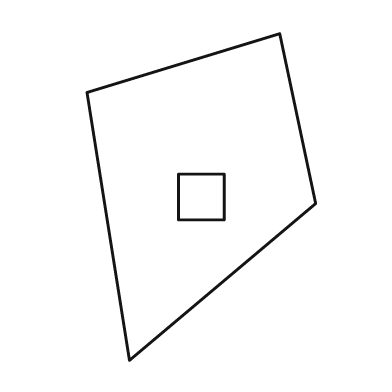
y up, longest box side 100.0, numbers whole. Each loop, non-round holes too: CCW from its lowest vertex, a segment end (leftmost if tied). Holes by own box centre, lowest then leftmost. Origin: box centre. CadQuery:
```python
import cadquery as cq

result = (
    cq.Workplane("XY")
    .moveTo(-22.0, -50.0)
    .lineTo(35.0, -2.0)
    .lineTo(24.0, 50.0)
    .lineTo(-35.0, 32.0)
    .close()
    .moveTo(-7.0, -7.0)
    .lineTo(7.0, -7.0)
    .lineTo(7.0, 7.0)
    .lineTo(-7.0, 7.0)
    .close()
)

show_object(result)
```